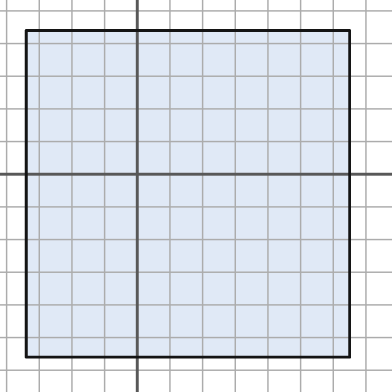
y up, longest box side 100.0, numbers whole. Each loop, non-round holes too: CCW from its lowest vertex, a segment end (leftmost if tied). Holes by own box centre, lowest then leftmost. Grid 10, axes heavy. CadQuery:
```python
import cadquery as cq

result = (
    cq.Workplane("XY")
    .moveTo(-34.0, -56.0)
    .lineTo(65.0, -56.0)
    .lineTo(65.0, 44.0)
    .lineTo(-34.0, 44.0)
    .close()
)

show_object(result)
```